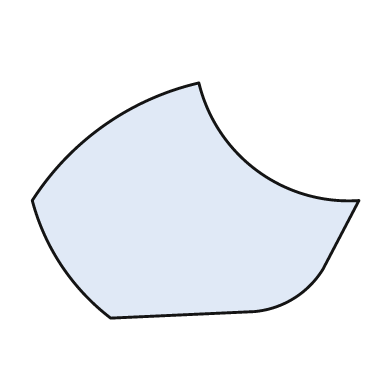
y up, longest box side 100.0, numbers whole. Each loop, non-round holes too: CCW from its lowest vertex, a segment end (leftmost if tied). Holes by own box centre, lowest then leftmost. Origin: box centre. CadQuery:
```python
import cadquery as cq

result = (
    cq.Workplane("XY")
    .moveTo(-26.0, -36.0)
    .lineTo(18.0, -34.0)
    .threePointArc((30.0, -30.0), (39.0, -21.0))
    .lineTo(50.0, 0.0)
    .threePointArc((19.0, 9.0), (1.0, 36.0))
    .threePointArc((-28.0, 23.0), (-50.0, 0.0))
    .threePointArc((-41.0, -20.0), (-26.0, -36.0))
    .close()
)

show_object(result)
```